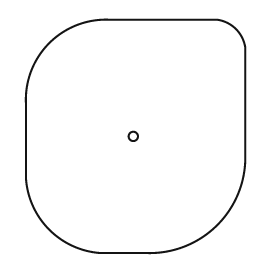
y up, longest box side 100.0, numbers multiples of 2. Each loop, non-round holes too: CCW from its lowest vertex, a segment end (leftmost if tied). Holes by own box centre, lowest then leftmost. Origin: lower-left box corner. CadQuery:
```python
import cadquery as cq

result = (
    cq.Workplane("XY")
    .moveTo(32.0, 0.0)
    .lineTo(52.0, 0.0)
    .threePointArc((82.0, 12.0), (94.0, 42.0))
    .lineTo(94.0, 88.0)
    .threePointArc((90.0, 96.0), (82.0, 100.0))
    .lineTo(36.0, 100.0)
    .threePointArc((10.0, 90.0), (0.0, 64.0))
    .lineTo(0.0, 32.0)
    .threePointArc((10.0, 10.0), (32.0, 0.0))
    .close()
    .moveTo(46.0, 50.0)
    .circle(2.0)
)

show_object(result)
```